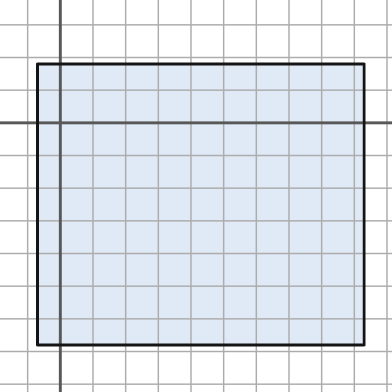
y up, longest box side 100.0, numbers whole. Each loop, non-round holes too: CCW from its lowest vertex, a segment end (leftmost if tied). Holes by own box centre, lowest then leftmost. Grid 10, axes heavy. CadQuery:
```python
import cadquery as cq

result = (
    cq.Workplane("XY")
    .moveTo(-7.0, -68.0)
    .lineTo(93.0, -68.0)
    .lineTo(93.0, 18.0)
    .lineTo(-7.0, 18.0)
    .close()
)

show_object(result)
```